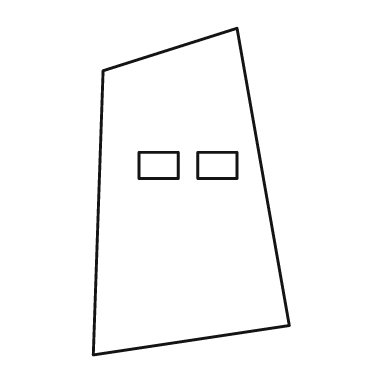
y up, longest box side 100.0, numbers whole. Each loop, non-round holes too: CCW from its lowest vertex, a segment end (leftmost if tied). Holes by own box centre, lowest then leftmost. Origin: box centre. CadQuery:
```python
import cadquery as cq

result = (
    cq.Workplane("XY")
    .moveTo(-30.0, -50.0)
    .lineTo(30.0, -41.0)
    .lineTo(14.0, 50.0)
    .lineTo(-27.0, 37.0)
    .close()
    .moveTo(-16.0, 4.0)
    .lineTo(-4.0, 4.0)
    .lineTo(-4.0, 12.0)
    .lineTo(-16.0, 12.0)
    .close()
    .moveTo(2.0, 4.0)
    .lineTo(14.0, 4.0)
    .lineTo(14.0, 12.0)
    .lineTo(2.0, 12.0)
    .close()
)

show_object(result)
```